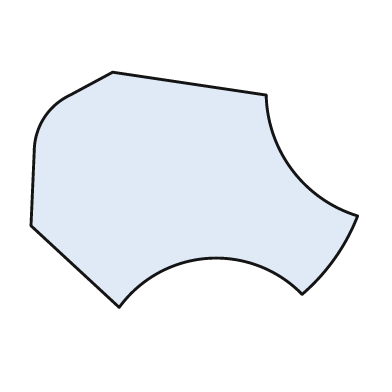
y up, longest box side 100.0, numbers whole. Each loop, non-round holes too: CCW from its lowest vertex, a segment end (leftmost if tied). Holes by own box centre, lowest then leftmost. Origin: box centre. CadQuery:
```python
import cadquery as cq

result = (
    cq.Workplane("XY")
    .moveTo(-23.0, -36.0)
    .threePointArc((4.0, -21.0), (33.0, -32.0))
    .threePointArc((43.0, -21.0), (50.0, -8.0))
    .threePointArc((30.0, 6.0), (22.0, 29.0))
    .lineTo(-25.0, 36.0)
    .lineTo(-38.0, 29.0)
    .threePointArc((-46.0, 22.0), (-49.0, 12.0))
    .lineTo(-50.0, -11.0)
    .close()
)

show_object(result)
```